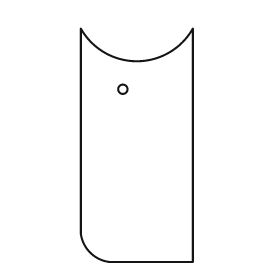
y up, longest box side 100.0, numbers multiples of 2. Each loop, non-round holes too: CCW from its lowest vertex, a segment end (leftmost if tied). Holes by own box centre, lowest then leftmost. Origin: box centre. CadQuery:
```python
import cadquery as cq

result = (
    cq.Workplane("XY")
    .moveTo(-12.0, -50.0)
    .lineTo(24.0, -50.0)
    .lineTo(24.0, 50.0)
    .threePointArc((0.0, 36.0), (-24.0, 50.0))
    .lineTo(-24.0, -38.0)
    .threePointArc((-20.0, -46.0), (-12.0, -50.0))
    .close()
    .moveTo(-6.0, 24.0)
    .circle(2.0)
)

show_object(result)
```